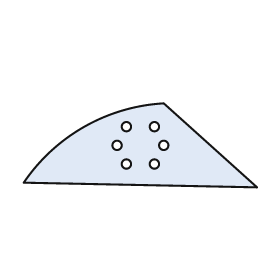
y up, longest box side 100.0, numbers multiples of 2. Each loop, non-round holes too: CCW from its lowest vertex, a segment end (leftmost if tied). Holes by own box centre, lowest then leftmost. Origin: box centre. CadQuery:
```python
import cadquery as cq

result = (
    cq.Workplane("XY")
    .moveTo(50.0, -18.0)
    .lineTo(10.0, 18.0)
    .threePointArc((-24.0, 8.0), (-50.0, -16.0))
    .close()
    .moveTo(-6.0, -8.0)
    .circle(2.0)
    .moveTo(6.0, -8.0)
    .circle(2.0)
    .moveTo(-10.0, 0.0)
    .circle(2.0)
    .moveTo(10.0, 0.0)
    .circle(2.0)
    .moveTo(-6.0, 8.0)
    .circle(2.0)
    .moveTo(6.0, 8.0)
    .circle(2.0)
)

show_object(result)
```